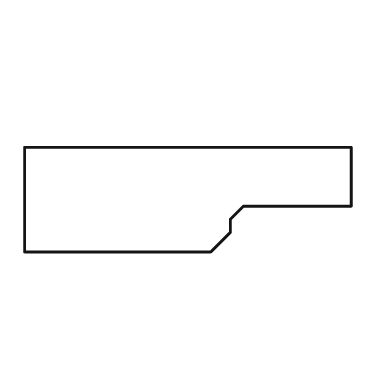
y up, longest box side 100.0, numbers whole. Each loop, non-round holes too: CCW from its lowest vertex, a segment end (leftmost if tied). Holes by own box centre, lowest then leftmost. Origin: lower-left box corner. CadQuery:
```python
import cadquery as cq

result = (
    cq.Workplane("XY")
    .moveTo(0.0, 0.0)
    .lineTo(57.0, 0.0)
    .lineTo(63.0, 6.0)
    .lineTo(63.0, 10.0)
    .lineTo(67.0, 14.0)
    .lineTo(100.0, 14.0)
    .lineTo(100.0, 32.0)
    .lineTo(0.0, 32.0)
    .close()
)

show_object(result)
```